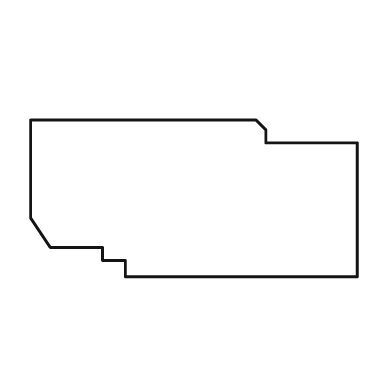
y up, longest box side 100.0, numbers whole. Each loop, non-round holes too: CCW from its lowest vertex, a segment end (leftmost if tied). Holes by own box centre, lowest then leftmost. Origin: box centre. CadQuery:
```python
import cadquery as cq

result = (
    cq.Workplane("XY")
    .moveTo(-21.0, -24.0)
    .lineTo(50.0, -24.0)
    .lineTo(50.0, 17.0)
    .lineTo(22.0, 17.0)
    .lineTo(22.0, 21.0)
    .lineTo(19.0, 24.0)
    .lineTo(-50.0, 24.0)
    .lineTo(-50.0, -6.0)
    .lineTo(-44.0, -15.0)
    .lineTo(-28.0, -15.0)
    .lineTo(-28.0, -19.0)
    .lineTo(-21.0, -19.0)
    .close()
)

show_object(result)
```